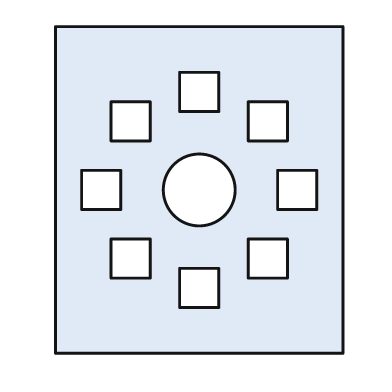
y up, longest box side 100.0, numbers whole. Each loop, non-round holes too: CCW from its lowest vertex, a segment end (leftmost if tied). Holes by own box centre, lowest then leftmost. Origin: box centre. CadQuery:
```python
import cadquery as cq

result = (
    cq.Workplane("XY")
    .moveTo(-44.0, -50.0)
    .lineTo(44.0, -50.0)
    .lineTo(44.0, 50.0)
    .lineTo(-44.0, 50.0)
    .close()
    .moveTo(-6.0, -36.0)
    .lineTo(6.0, -36.0)
    .lineTo(6.0, -24.0)
    .lineTo(-6.0, -24.0)
    .close()
    .moveTo(-27.0, -27.0)
    .lineTo(-15.0, -27.0)
    .lineTo(-15.0, -15.0)
    .lineTo(-27.0, -15.0)
    .close()
    .moveTo(15.0, -27.0)
    .lineTo(27.0, -27.0)
    .lineTo(27.0, -15.0)
    .lineTo(15.0, -15.0)
    .close()
    .moveTo(-36.0, -6.0)
    .lineTo(-24.0, -6.0)
    .lineTo(-24.0, 6.0)
    .lineTo(-36.0, 6.0)
    .close()
    .moveTo(0.0, 0.0)
    .circle(11.0)
    .moveTo(24.0, -6.0)
    .lineTo(36.0, -6.0)
    .lineTo(36.0, 6.0)
    .lineTo(24.0, 6.0)
    .close()
    .moveTo(-27.0, 15.0)
    .lineTo(-15.0, 15.0)
    .lineTo(-15.0, 27.0)
    .lineTo(-27.0, 27.0)
    .close()
    .moveTo(15.0, 15.0)
    .lineTo(27.0, 15.0)
    .lineTo(27.0, 27.0)
    .lineTo(15.0, 27.0)
    .close()
    .moveTo(-6.0, 24.0)
    .lineTo(6.0, 24.0)
    .lineTo(6.0, 36.0)
    .lineTo(-6.0, 36.0)
    .close()
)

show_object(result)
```